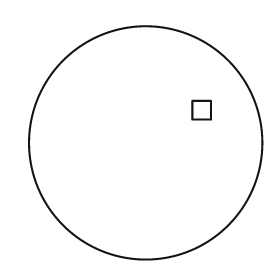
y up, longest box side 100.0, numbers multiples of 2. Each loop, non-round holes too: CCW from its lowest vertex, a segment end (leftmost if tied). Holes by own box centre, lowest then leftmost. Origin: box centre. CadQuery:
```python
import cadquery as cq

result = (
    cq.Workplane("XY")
    .moveTo(0.0, 0.0)
    .circle(50.0)
    .moveTo(20.0, 10.0)
    .lineTo(28.0, 10.0)
    .lineTo(28.0, 18.0)
    .lineTo(20.0, 18.0)
    .close()
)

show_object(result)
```